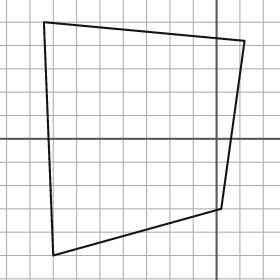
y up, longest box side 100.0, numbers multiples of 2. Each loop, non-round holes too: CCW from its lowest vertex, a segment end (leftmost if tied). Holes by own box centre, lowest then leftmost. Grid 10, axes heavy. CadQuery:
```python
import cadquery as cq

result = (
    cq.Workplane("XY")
    .moveTo(-70.0, -50.0)
    .lineTo(2.0, -30.0)
    .lineTo(12.0, 42.0)
    .lineTo(-74.0, 50.0)
    .close()
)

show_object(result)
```